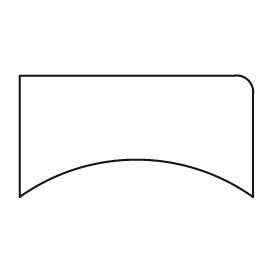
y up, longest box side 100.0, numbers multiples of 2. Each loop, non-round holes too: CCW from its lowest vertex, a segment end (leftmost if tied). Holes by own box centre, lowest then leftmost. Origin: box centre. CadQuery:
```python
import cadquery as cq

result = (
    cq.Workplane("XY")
    .moveTo(-50.0, -26.0)
    .threePointArc((0.0, -10.0), (50.0, -26.0))
    .lineTo(50.0, 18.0)
    .threePointArc((48.0, 24.0), (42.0, 26.0))
    .lineTo(-50.0, 26.0)
    .close()
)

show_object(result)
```